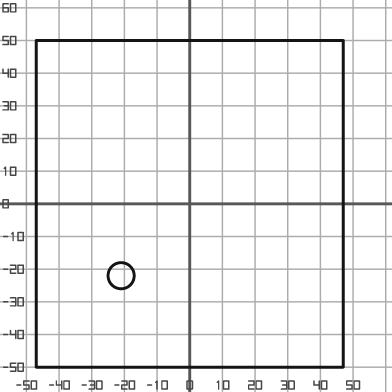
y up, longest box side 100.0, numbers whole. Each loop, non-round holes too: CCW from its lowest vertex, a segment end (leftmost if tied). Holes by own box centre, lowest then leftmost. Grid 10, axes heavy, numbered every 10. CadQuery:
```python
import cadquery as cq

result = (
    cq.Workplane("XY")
    .moveTo(-47.0, -50.0)
    .lineTo(47.0, -50.0)
    .lineTo(47.0, 50.0)
    .lineTo(-47.0, 50.0)
    .close()
    .moveTo(-21.0, -22.0)
    .circle(4.0)
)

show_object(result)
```